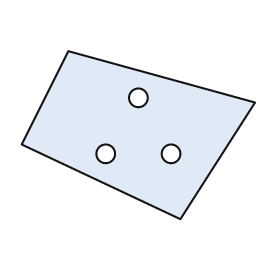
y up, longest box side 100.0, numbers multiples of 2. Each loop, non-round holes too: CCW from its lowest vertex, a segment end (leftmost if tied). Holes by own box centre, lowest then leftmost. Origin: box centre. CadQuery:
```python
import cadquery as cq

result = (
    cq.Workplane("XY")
    .moveTo(18.0, -36.0)
    .lineTo(50.0, 14.0)
    .lineTo(-30.0, 36.0)
    .lineTo(-50.0, -4.0)
    .close()
    .moveTo(-14.0, -8.0)
    .circle(4.0)
    .moveTo(14.0, -8.0)
    .circle(4.0)
    .moveTo(0.0, 16.0)
    .circle(4.0)
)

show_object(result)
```